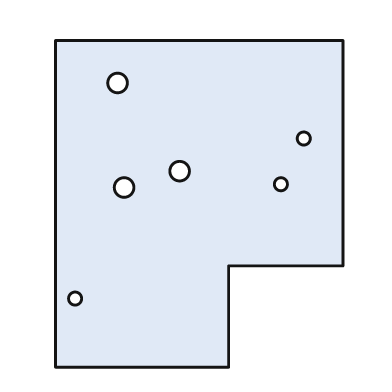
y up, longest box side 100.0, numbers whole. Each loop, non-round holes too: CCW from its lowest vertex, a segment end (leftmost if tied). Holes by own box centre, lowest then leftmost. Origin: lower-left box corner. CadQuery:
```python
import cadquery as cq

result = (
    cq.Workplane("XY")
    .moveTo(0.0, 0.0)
    .lineTo(53.0, 0.0)
    .lineTo(53.0, 31.0)
    .lineTo(88.0, 31.0)
    .lineTo(88.0, 100.0)
    .lineTo(0.0, 100.0)
    .close()
    .moveTo(6.0, 21.0)
    .circle(2.0)
    .moveTo(21.0, 55.0)
    .circle(3.0)
    .moveTo(69.0, 56.0)
    .circle(2.0)
    .moveTo(38.0, 60.0)
    .circle(3.0)
    .moveTo(76.0, 70.0)
    .circle(2.0)
    .moveTo(19.0, 87.0)
    .circle(3.0)
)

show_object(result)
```